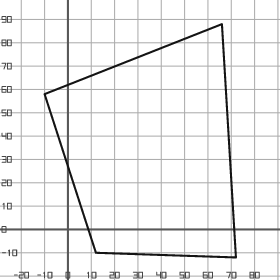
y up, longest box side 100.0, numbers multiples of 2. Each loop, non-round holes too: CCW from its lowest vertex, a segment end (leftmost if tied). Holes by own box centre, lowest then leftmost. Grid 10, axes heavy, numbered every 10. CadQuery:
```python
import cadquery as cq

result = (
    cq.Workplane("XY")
    .moveTo(72.0, -12.0)
    .lineTo(66.0, 88.0)
    .lineTo(-10.0, 58.0)
    .lineTo(12.0, -10.0)
    .close()
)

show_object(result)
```